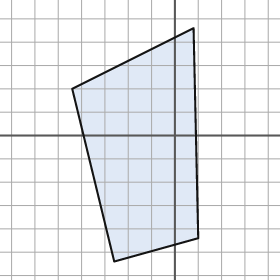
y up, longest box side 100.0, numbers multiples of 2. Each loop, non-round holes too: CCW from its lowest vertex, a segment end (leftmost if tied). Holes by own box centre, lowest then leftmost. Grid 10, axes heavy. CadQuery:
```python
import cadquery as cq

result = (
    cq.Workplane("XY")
    .moveTo(-26.0, -54.0)
    .lineTo(10.0, -44.0)
    .lineTo(8.0, 46.0)
    .lineTo(-44.0, 20.0)
    .close()
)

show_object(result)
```